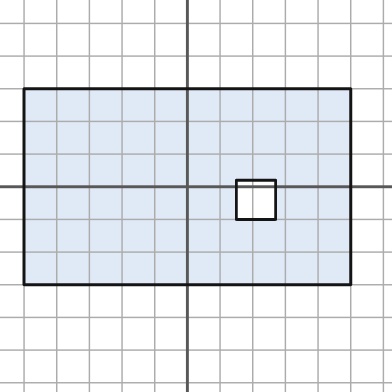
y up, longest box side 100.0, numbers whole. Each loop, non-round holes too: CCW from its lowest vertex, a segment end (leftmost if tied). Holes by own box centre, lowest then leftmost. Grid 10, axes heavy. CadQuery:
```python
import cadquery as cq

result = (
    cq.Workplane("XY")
    .moveTo(-50.0, -30.0)
    .lineTo(50.0, -30.0)
    .lineTo(50.0, 30.0)
    .lineTo(-50.0, 30.0)
    .close()
    .moveTo(15.0, -10.0)
    .lineTo(27.0, -10.0)
    .lineTo(27.0, 2.0)
    .lineTo(15.0, 2.0)
    .close()
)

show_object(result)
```